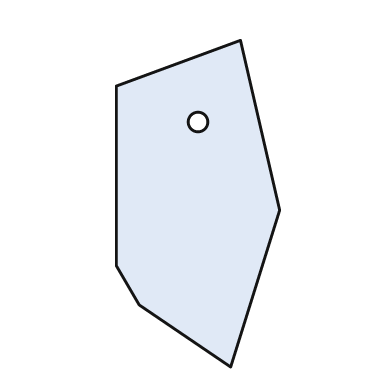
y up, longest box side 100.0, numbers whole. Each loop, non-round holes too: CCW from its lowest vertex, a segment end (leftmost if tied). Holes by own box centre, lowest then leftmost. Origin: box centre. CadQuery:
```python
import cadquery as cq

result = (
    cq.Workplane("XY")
    .moveTo(10.0, -50.0)
    .lineTo(25.0, -2.0)
    .lineTo(13.0, 50.0)
    .lineTo(-25.0, 36.0)
    .lineTo(-25.0, -19.0)
    .lineTo(-18.0, -31.0)
    .close()
    .moveTo(0.0, 25.0)
    .circle(3.0)
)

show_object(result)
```